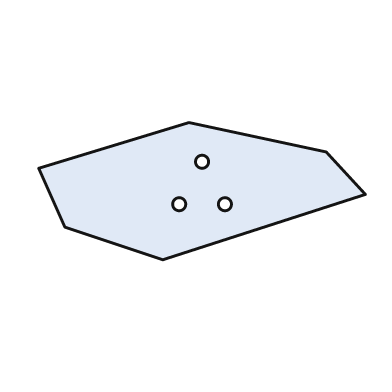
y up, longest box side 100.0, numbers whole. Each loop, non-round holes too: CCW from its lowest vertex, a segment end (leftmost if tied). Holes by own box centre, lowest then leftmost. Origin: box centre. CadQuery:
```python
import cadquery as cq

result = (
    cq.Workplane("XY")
    .moveTo(-12.0, -21.0)
    .lineTo(50.0, -1.0)
    .lineTo(38.0, 12.0)
    .lineTo(-4.0, 21.0)
    .lineTo(-50.0, 7.0)
    .lineTo(-42.0, -11.0)
    .close()
    .moveTo(-7.0, -4.0)
    .circle(2.0)
    .moveTo(7.0, -4.0)
    .circle(2.0)
    .moveTo(0.0, 9.0)
    .circle(2.0)
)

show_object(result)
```